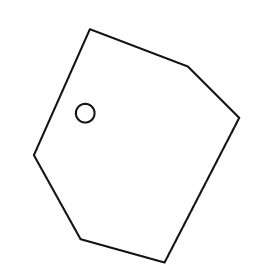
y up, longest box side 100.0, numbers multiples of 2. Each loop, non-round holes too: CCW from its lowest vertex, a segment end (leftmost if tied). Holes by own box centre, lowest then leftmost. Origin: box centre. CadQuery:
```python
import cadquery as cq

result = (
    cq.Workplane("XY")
    .moveTo(12.0, -50.0)
    .lineTo(44.0, 12.0)
    .lineTo(22.0, 34.0)
    .lineTo(-20.0, 50.0)
    .lineTo(-44.0, -4.0)
    .lineTo(-24.0, -40.0)
    .close()
    .moveTo(-22.0, 14.0)
    .circle(4.0)
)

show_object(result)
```